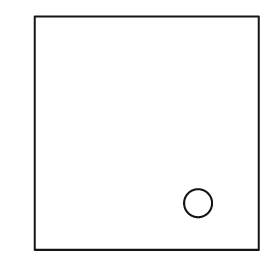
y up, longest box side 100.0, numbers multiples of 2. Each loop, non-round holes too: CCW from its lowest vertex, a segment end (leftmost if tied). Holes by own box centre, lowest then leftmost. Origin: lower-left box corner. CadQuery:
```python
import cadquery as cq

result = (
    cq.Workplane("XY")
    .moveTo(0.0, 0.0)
    .lineTo(96.0, 0.0)
    .lineTo(96.0, 100.0)
    .lineTo(0.0, 100.0)
    .close()
    .moveTo(70.0, 20.0)
    .circle(6.0)
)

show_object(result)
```